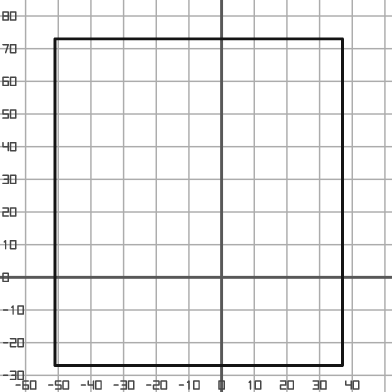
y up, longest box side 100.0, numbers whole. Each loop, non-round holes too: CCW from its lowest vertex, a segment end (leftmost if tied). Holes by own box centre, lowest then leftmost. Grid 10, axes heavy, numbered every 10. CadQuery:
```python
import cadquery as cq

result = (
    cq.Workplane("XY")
    .moveTo(-51.0, -27.0)
    .lineTo(37.0, -27.0)
    .lineTo(37.0, 73.0)
    .lineTo(-51.0, 73.0)
    .close()
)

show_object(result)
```